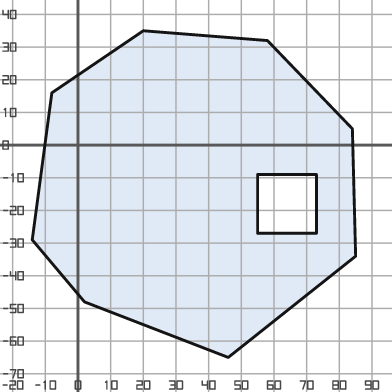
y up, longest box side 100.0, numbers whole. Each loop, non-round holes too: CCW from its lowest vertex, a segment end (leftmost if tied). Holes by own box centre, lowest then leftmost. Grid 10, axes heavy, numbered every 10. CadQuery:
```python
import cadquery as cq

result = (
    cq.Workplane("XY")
    .moveTo(46.0, -65.0)
    .lineTo(85.0, -34.0)
    .lineTo(84.0, 5.0)
    .lineTo(58.0, 32.0)
    .lineTo(20.0, 35.0)
    .lineTo(-8.0, 16.0)
    .lineTo(-14.0, -29.0)
    .lineTo(2.0, -48.0)
    .close()
    .moveTo(55.0, -27.0)
    .lineTo(73.0, -27.0)
    .lineTo(73.0, -9.0)
    .lineTo(55.0, -9.0)
    .close()
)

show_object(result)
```